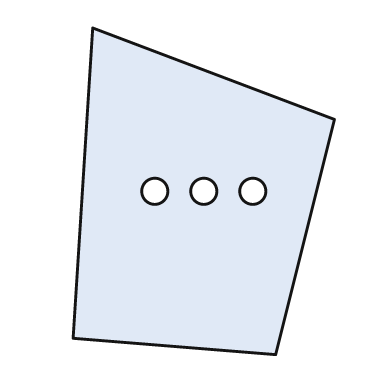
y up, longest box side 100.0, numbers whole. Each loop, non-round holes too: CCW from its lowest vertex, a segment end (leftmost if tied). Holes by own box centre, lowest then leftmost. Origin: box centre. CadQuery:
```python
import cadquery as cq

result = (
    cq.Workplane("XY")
    .moveTo(22.0, -50.0)
    .lineTo(40.0, 22.0)
    .lineTo(-34.0, 50.0)
    .lineTo(-40.0, -45.0)
    .close()
    .moveTo(-15.0, 0.0)
    .circle(4.0)
    .moveTo(0.0, 0.0)
    .circle(4.0)
    .moveTo(15.0, 0.0)
    .circle(4.0)
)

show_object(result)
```